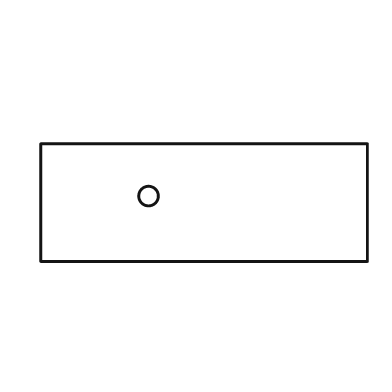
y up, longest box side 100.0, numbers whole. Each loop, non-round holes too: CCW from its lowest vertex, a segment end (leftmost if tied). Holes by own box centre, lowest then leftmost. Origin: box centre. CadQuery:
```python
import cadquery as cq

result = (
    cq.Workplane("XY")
    .moveTo(-50.0, -18.0)
    .lineTo(50.0, -18.0)
    .lineTo(50.0, 18.0)
    .lineTo(-50.0, 18.0)
    .close()
    .moveTo(-17.0, 2.0)
    .circle(3.0)
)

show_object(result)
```